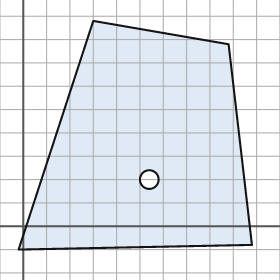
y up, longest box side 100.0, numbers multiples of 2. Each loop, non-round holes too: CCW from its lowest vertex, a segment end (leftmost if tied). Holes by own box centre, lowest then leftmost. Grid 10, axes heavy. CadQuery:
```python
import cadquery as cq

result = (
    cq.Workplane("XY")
    .moveTo(-2.0, -10.0)
    .lineTo(98.0, -8.0)
    .lineTo(88.0, 78.0)
    .lineTo(30.0, 88.0)
    .close()
    .moveTo(54.0, 20.0)
    .circle(4.0)
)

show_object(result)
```